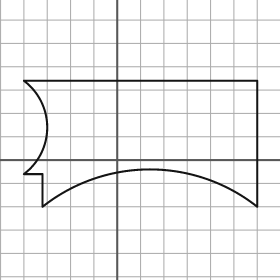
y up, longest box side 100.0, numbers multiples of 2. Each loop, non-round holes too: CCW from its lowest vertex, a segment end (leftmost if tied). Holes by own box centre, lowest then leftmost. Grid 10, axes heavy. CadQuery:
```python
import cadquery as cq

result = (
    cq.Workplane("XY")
    .moveTo(-32.0, -20.0)
    .threePointArc((14.0, -4.0), (60.0, -20.0))
    .lineTo(60.0, 34.0)
    .lineTo(-40.0, 34.0)
    .threePointArc((-30.0, 14.0), (-40.0, -6.0))
    .lineTo(-32.0, -6.0)
    .close()
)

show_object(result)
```